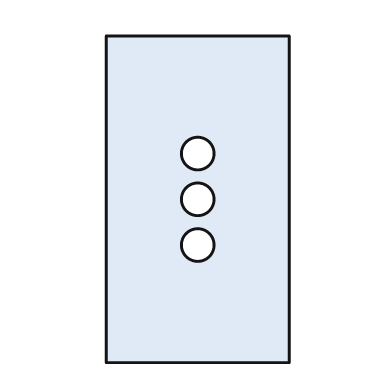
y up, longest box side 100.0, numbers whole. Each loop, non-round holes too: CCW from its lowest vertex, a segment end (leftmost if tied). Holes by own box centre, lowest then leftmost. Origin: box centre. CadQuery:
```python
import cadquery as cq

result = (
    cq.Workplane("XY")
    .moveTo(-28.0, -50.0)
    .lineTo(28.0, -50.0)
    .lineTo(28.0, 50.0)
    .lineTo(-28.0, 50.0)
    .close()
    .moveTo(0.0, -14.0)
    .circle(5.0)
    .moveTo(0.0, 0.0)
    .circle(5.0)
    .moveTo(0.0, 14.0)
    .circle(5.0)
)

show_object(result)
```